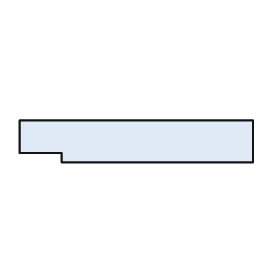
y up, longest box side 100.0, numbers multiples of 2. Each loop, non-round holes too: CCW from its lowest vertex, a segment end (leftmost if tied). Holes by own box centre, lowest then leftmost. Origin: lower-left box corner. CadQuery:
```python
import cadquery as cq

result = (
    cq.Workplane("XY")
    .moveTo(18.0, 0.0)
    .lineTo(100.0, 0.0)
    .lineTo(100.0, 18.0)
    .lineTo(0.0, 18.0)
    .lineTo(0.0, 4.0)
    .lineTo(18.0, 4.0)
    .close()
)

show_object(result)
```